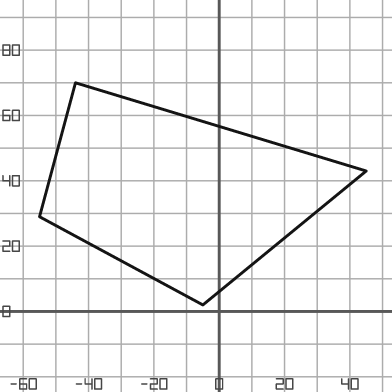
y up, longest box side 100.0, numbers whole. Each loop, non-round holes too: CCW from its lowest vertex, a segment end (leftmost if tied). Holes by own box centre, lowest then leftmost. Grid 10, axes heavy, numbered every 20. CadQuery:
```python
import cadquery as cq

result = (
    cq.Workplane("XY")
    .moveTo(-5.0, 2.0)
    .lineTo(45.0, 43.0)
    .lineTo(-44.0, 70.0)
    .lineTo(-55.0, 29.0)
    .close()
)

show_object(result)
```